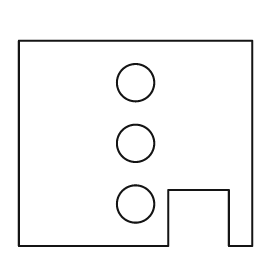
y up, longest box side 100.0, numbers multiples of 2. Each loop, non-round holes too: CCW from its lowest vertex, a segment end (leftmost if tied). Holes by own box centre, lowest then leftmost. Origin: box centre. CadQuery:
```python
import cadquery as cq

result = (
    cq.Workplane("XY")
    .moveTo(-50.0, -44.0)
    .lineTo(14.0, -44.0)
    .lineTo(14.0, -20.0)
    .lineTo(40.0, -20.0)
    .lineTo(40.0, -44.0)
    .lineTo(50.0, -44.0)
    .lineTo(50.0, 44.0)
    .lineTo(-50.0, 44.0)
    .close()
    .moveTo(0.0, -26.0)
    .circle(8.0)
    .moveTo(0.0, 0.0)
    .circle(8.0)
    .moveTo(0.0, 26.0)
    .circle(8.0)
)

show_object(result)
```